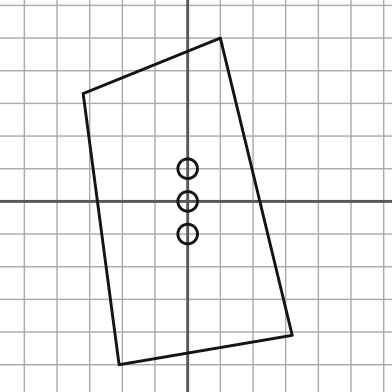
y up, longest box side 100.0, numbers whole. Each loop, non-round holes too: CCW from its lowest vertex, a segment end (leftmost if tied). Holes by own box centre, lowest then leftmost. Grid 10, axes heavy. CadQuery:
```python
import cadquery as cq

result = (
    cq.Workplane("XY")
    .moveTo(-21.0, -50.0)
    .lineTo(32.0, -41.0)
    .lineTo(10.0, 50.0)
    .lineTo(-32.0, 33.0)
    .close()
    .moveTo(0.0, -10.0)
    .circle(3.0)
    .moveTo(0.0, 0.0)
    .circle(3.0)
    .moveTo(0.0, 10.0)
    .circle(3.0)
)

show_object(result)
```